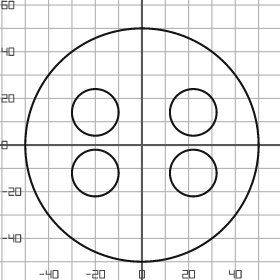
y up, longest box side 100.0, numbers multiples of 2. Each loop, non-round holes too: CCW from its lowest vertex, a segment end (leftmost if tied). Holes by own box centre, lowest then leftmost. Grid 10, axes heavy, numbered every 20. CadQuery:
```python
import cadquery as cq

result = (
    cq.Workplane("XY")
    .moveTo(0.0, 0.0)
    .circle(50.0)
    .moveTo(-20.0, -12.0)
    .circle(10.0)
    .moveTo(22.0, -12.0)
    .circle(10.0)
    .moveTo(-20.0, 14.0)
    .circle(10.0)
    .moveTo(22.0, 14.0)
    .circle(10.0)
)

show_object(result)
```